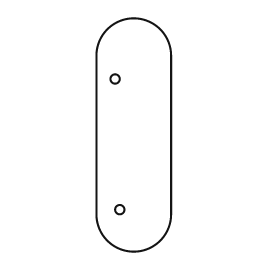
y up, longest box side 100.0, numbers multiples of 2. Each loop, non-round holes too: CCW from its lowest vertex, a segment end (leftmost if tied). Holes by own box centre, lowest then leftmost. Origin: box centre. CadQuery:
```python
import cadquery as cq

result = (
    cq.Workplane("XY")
    .moveTo(-16.0, -34.0)
    .threePointArc((0.0, -50.0), (16.0, -34.0))
    .lineTo(16.0, 34.0)
    .threePointArc((0.0, 50.0), (-16.0, 34.0))
    .close()
    .moveTo(-6.0, -32.0)
    .circle(2.0)
    .moveTo(-8.0, 24.0)
    .circle(2.0)
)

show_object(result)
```